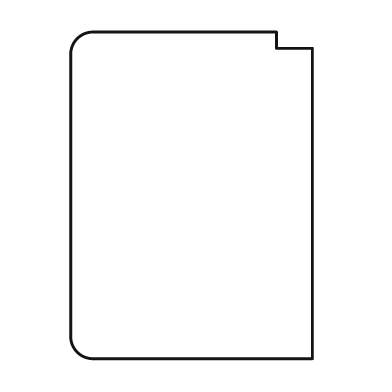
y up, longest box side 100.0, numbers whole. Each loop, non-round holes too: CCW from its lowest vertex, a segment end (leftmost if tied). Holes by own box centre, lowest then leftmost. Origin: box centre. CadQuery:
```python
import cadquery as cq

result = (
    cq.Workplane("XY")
    .moveTo(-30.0, -50.0)
    .lineTo(37.0, -50.0)
    .lineTo(37.0, 45.0)
    .lineTo(26.0, 45.0)
    .lineTo(26.0, 50.0)
    .lineTo(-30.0, 50.0)
    .threePointArc((-35.0, 48.0), (-37.0, 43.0))
    .lineTo(-37.0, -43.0)
    .threePointArc((-35.0, -48.0), (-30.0, -50.0))
    .close()
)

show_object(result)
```